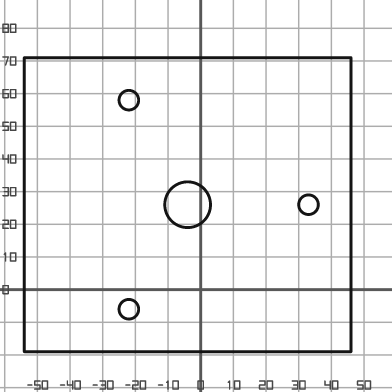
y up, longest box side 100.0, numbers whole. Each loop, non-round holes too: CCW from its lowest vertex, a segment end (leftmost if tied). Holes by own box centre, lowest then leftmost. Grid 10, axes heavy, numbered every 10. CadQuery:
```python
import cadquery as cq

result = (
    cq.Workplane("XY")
    .moveTo(-54.0, -19.0)
    .lineTo(46.0, -19.0)
    .lineTo(46.0, 71.0)
    .lineTo(-54.0, 71.0)
    .close()
    .moveTo(-22.0, -6.0)
    .circle(3.0)
    .moveTo(-4.0, 26.0)
    .circle(7.0)
    .moveTo(33.0, 26.0)
    .circle(3.0)
    .moveTo(-22.0, 58.0)
    .circle(3.0)
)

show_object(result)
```